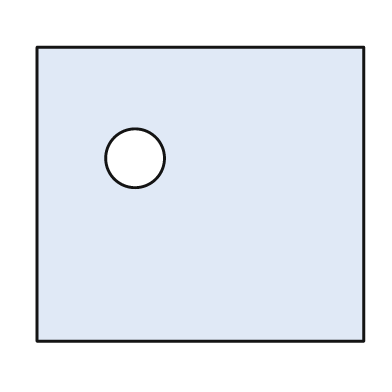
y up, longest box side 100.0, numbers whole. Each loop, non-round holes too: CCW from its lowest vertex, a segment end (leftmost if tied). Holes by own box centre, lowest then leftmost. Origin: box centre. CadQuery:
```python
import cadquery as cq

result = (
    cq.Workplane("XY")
    .moveTo(-50.0, -45.0)
    .lineTo(50.0, -45.0)
    .lineTo(50.0, 45.0)
    .lineTo(-50.0, 45.0)
    .close()
    .moveTo(-20.0, 11.0)
    .circle(9.0)
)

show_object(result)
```